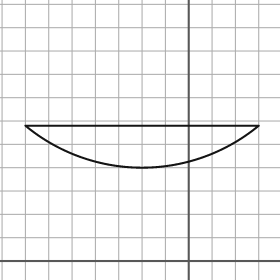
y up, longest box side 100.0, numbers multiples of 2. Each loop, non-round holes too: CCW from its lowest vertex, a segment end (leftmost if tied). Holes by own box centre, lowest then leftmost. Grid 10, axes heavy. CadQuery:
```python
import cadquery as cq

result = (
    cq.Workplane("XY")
    .moveTo(-70.0, 58.0)
    .threePointArc((-20.0, 40.0), (30.0, 58.0))
    .close()
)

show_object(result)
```